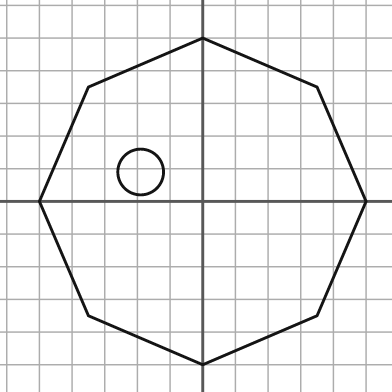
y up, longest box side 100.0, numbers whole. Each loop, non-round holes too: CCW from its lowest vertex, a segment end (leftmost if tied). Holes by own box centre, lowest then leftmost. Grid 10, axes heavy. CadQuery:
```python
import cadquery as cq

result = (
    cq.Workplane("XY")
    .moveTo(0.0, -50.0)
    .lineTo(35.0, -35.0)
    .lineTo(50.0, 0.0)
    .lineTo(35.0, 35.0)
    .lineTo(0.0, 50.0)
    .lineTo(-35.0, 35.0)
    .lineTo(-50.0, 0.0)
    .lineTo(-35.0, -35.0)
    .close()
    .moveTo(-19.0, 9.0)
    .circle(7.0)
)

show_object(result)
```